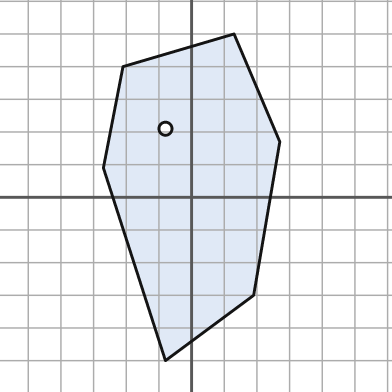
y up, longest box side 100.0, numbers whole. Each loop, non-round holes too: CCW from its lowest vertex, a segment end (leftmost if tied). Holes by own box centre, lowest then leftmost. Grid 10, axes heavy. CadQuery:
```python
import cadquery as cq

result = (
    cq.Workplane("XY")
    .moveTo(-8.0, -50.0)
    .lineTo(19.0, -30.0)
    .lineTo(27.0, 17.0)
    .lineTo(13.0, 50.0)
    .lineTo(-21.0, 40.0)
    .lineTo(-27.0, 9.0)
    .close()
    .moveTo(-8.0, 21.0)
    .circle(2.0)
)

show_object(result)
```